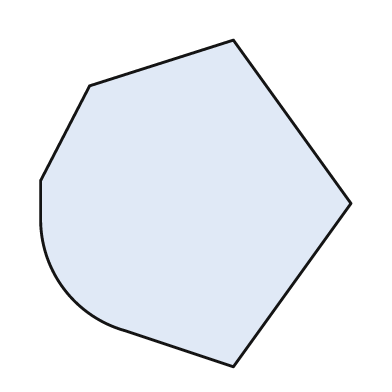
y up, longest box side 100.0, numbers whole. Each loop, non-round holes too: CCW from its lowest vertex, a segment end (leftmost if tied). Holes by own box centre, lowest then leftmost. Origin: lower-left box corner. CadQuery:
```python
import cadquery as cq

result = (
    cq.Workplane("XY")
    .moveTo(59.0, 0.0)
    .lineTo(95.0, 50.0)
    .lineTo(59.0, 100.0)
    .lineTo(15.0, 86.0)
    .lineTo(0.0, 57.0)
    .lineTo(0.0, 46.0)
    .threePointArc((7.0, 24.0), (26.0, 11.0))
    .close()
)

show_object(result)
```